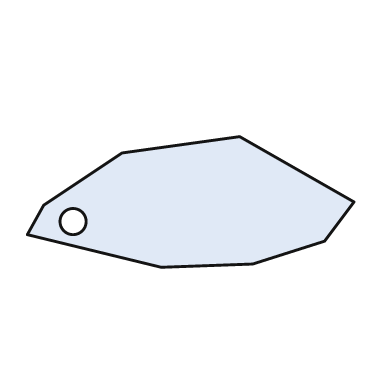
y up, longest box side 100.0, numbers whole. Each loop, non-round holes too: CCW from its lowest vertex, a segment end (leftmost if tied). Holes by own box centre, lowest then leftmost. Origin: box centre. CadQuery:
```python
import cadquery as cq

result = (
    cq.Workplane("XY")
    .moveTo(-9.0, -20.0)
    .lineTo(19.0, -19.0)
    .lineTo(41.0, -12.0)
    .lineTo(50.0, 0.0)
    .lineTo(15.0, 20.0)
    .lineTo(-21.0, 15.0)
    .lineTo(-45.0, -1.0)
    .lineTo(-50.0, -10.0)
    .close()
    .moveTo(-36.0, -6.0)
    .circle(4.0)
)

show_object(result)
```